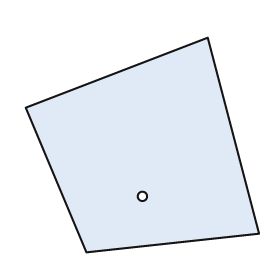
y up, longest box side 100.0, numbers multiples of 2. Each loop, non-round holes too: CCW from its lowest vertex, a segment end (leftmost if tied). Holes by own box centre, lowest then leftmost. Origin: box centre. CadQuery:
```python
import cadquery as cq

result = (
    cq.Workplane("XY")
    .moveTo(-24.0, -46.0)
    .lineTo(50.0, -38.0)
    .lineTo(28.0, 46.0)
    .lineTo(-50.0, 16.0)
    .close()
    .moveTo(0.0, -22.0)
    .circle(2.0)
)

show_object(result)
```